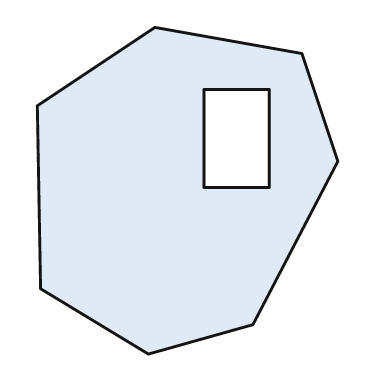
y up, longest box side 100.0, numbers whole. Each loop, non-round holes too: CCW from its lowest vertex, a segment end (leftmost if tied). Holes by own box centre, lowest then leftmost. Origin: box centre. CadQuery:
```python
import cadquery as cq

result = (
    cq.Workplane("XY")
    .moveTo(-12.0, -50.0)
    .lineTo(20.0, -41.0)
    .lineTo(46.0, 9.0)
    .lineTo(35.0, 42.0)
    .lineTo(-10.0, 50.0)
    .lineTo(-46.0, 26.0)
    .lineTo(-45.0, -30.0)
    .close()
    .moveTo(5.0, 1.0)
    .lineTo(25.0, 1.0)
    .lineTo(25.0, 31.0)
    .lineTo(5.0, 31.0)
    .close()
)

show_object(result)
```